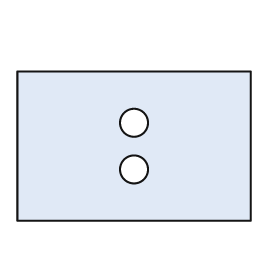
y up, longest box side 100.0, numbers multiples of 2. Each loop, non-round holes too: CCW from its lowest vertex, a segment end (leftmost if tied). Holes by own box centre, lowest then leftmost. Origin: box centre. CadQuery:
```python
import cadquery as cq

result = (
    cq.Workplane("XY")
    .moveTo(-50.0, -32.0)
    .lineTo(50.0, -32.0)
    .lineTo(50.0, 32.0)
    .lineTo(-50.0, 32.0)
    .close()
    .moveTo(0.0, -10.0)
    .circle(6.0)
    .moveTo(0.0, 10.0)
    .circle(6.0)
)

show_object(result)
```